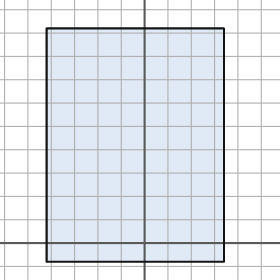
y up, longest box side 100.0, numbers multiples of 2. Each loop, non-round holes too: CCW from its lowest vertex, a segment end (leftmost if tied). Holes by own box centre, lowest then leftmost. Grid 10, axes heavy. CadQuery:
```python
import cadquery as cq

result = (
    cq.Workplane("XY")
    .moveTo(-42.0, -8.0)
    .lineTo(34.0, -8.0)
    .lineTo(34.0, 92.0)
    .lineTo(-42.0, 92.0)
    .close()
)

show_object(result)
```